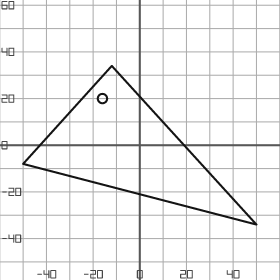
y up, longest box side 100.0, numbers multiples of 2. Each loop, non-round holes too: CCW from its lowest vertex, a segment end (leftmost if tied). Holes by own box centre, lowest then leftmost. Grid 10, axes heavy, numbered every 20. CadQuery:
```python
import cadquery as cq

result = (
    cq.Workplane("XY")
    .moveTo(50.0, -34.0)
    .lineTo(-12.0, 34.0)
    .lineTo(-50.0, -8.0)
    .close()
    .moveTo(-16.0, 20.0)
    .circle(2.0)
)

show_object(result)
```